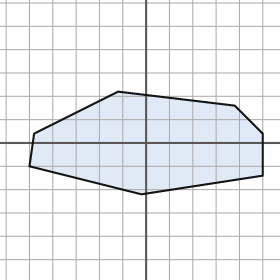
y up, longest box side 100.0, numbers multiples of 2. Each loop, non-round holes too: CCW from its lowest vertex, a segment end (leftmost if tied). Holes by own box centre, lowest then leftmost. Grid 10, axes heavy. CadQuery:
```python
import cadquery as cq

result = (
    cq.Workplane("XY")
    .moveTo(-2.0, -22.0)
    .lineTo(50.0, -14.0)
    .lineTo(50.0, 4.0)
    .lineTo(38.0, 16.0)
    .lineTo(-12.0, 22.0)
    .lineTo(-48.0, 4.0)
    .lineTo(-50.0, -10.0)
    .close()
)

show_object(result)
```